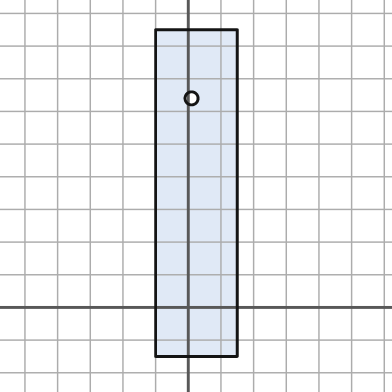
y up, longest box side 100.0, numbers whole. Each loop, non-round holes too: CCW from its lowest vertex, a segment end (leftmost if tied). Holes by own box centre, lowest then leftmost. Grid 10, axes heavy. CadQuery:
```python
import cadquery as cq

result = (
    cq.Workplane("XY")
    .moveTo(-10.0, -15.0)
    .lineTo(15.0, -15.0)
    .lineTo(15.0, 85.0)
    .lineTo(-10.0, 85.0)
    .close()
    .moveTo(1.0, 64.0)
    .circle(2.0)
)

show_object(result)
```